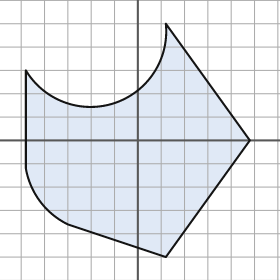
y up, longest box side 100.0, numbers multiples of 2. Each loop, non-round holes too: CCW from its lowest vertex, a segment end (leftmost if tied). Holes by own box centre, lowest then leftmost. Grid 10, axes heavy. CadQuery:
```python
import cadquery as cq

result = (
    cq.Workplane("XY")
    .moveTo(12.0, -50.0)
    .lineTo(48.0, 0.0)
    .lineTo(12.0, 50.0)
    .threePointArc((-10.0, 16.0), (-48.0, 30.0))
    .lineTo(-48.0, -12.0)
    .threePointArc((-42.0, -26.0), (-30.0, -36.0))
    .close()
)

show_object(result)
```